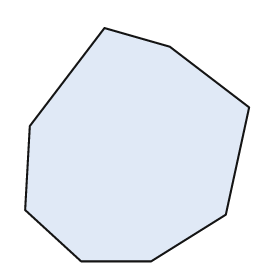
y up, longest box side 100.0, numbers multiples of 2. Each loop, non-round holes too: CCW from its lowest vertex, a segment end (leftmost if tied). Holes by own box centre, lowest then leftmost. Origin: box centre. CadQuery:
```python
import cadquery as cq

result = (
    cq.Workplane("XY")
    .moveTo(-24.0, -50.0)
    .lineTo(6.0, -50.0)
    .lineTo(38.0, -30.0)
    .lineTo(48.0, 16.0)
    .lineTo(14.0, 42.0)
    .lineTo(-14.0, 50.0)
    .lineTo(-46.0, 8.0)
    .lineTo(-48.0, -28.0)
    .close()
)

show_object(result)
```